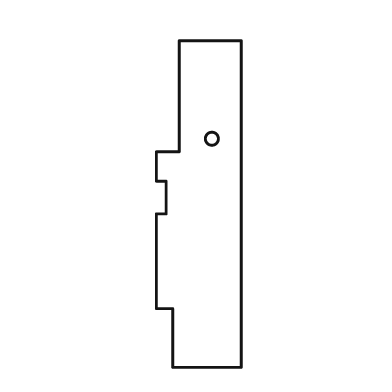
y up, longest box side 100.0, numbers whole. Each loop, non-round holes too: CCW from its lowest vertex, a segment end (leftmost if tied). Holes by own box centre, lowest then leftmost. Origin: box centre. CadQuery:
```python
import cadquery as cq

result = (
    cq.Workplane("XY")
    .moveTo(-8.0, -50.0)
    .lineTo(13.0, -50.0)
    .lineTo(13.0, 50.0)
    .lineTo(-6.0, 50.0)
    .lineTo(-6.0, 16.0)
    .lineTo(-13.0, 16.0)
    .lineTo(-13.0, 7.0)
    .lineTo(-10.0, 7.0)
    .lineTo(-10.0, -3.0)
    .lineTo(-13.0, -3.0)
    .lineTo(-13.0, -32.0)
    .lineTo(-8.0, -32.0)
    .close()
    .moveTo(4.0, 20.0)
    .circle(2.0)
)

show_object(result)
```